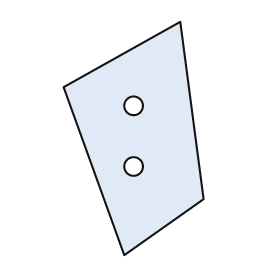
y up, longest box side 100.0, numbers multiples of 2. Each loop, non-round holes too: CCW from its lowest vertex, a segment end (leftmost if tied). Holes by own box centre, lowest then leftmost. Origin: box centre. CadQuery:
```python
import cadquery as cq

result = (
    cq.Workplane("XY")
    .moveTo(-4.0, -50.0)
    .lineTo(30.0, -26.0)
    .lineTo(20.0, 50.0)
    .lineTo(-30.0, 22.0)
    .close()
    .moveTo(0.0, -12.0)
    .circle(4.0)
    .moveTo(0.0, 14.0)
    .circle(4.0)
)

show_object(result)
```